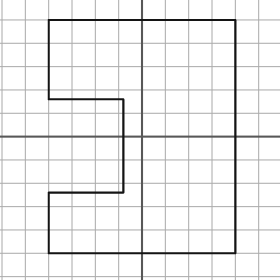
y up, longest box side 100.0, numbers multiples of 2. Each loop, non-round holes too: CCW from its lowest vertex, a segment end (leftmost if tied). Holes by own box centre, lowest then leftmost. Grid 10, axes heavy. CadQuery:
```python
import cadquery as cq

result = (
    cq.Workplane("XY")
    .moveTo(-40.0, -50.0)
    .lineTo(40.0, -50.0)
    .lineTo(40.0, 50.0)
    .lineTo(-40.0, 50.0)
    .lineTo(-40.0, 16.0)
    .lineTo(-8.0, 16.0)
    .lineTo(-8.0, -24.0)
    .lineTo(-40.0, -24.0)
    .close()
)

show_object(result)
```